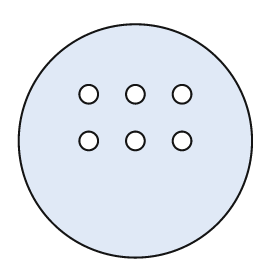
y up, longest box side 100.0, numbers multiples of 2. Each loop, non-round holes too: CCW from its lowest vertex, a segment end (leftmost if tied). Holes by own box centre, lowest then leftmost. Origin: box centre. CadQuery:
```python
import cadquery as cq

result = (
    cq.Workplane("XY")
    .moveTo(0.0, 0.0)
    .circle(50.0)
    .moveTo(-20.0, 0.0)
    .circle(4.0)
    .moveTo(0.0, 0.0)
    .circle(4.0)
    .moveTo(20.0, 0.0)
    .circle(4.0)
    .moveTo(-20.0, 20.0)
    .circle(4.0)
    .moveTo(0.0, 20.0)
    .circle(4.0)
    .moveTo(20.0, 20.0)
    .circle(4.0)
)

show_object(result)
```